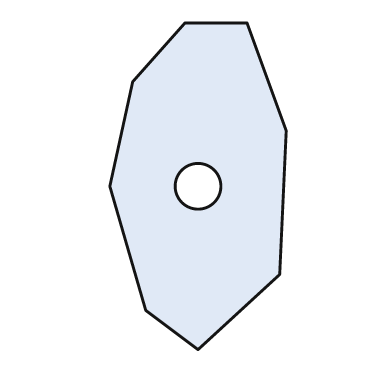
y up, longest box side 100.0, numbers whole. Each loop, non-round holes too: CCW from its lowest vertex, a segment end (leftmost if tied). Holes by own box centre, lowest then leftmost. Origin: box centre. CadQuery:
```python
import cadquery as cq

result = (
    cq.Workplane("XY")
    .moveTo(0.0, -50.0)
    .lineTo(25.0, -27.0)
    .lineTo(27.0, 17.0)
    .lineTo(15.0, 50.0)
    .lineTo(-4.0, 50.0)
    .lineTo(-20.0, 32.0)
    .lineTo(-27.0, 0.0)
    .lineTo(-16.0, -38.0)
    .close()
    .moveTo(0.0, 0.0)
    .circle(7.0)
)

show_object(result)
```